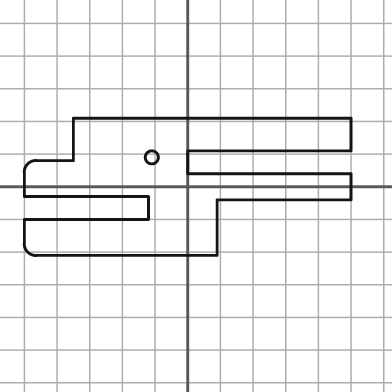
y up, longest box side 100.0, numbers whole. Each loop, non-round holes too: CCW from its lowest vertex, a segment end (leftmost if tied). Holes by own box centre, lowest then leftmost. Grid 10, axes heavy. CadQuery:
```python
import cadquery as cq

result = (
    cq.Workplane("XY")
    .moveTo(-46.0, -21.0)
    .lineTo(9.0, -21.0)
    .lineTo(9.0, -4.0)
    .lineTo(50.0, -4.0)
    .lineTo(50.0, 4.0)
    .lineTo(0.0, 4.0)
    .lineTo(0.0, 11.0)
    .lineTo(50.0, 11.0)
    .lineTo(50.0, 21.0)
    .lineTo(-35.0, 21.0)
    .lineTo(-35.0, 8.0)
    .lineTo(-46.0, 8.0)
    .threePointArc((-49.0, 7.0), (-50.0, 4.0))
    .lineTo(-50.0, -3.0)
    .lineTo(-12.0, -3.0)
    .lineTo(-12.0, -10.0)
    .lineTo(-50.0, -10.0)
    .lineTo(-50.0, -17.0)
    .threePointArc((-49.0, -20.0), (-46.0, -21.0))
    .close()
    .moveTo(-11.0, 9.0)
    .circle(2.0)
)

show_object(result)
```